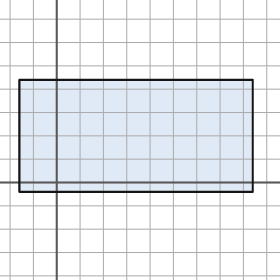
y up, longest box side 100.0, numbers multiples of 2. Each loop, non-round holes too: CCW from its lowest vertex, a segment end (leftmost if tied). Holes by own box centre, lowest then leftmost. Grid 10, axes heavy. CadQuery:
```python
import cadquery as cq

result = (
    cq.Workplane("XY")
    .moveTo(-16.0, -4.0)
    .lineTo(84.0, -4.0)
    .lineTo(84.0, 44.0)
    .lineTo(-16.0, 44.0)
    .close()
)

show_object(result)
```